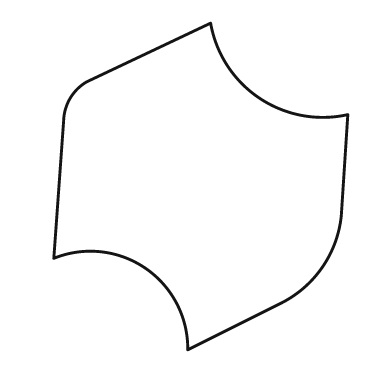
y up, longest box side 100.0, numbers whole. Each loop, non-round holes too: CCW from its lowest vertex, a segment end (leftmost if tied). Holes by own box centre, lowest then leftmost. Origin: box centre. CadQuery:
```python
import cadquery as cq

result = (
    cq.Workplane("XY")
    .moveTo(-4.0, -50.0)
    .lineTo(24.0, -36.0)
    .threePointArc((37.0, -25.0), (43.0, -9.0))
    .lineTo(45.0, 22.0)
    .threePointArc((18.0, 27.0), (3.0, 50.0))
    .lineTo(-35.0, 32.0)
    .threePointArc((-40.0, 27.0), (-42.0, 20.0))
    .lineTo(-45.0, -22.0)
    .threePointArc((-17.0, -25.0), (-4.0, -50.0))
    .close()
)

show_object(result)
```